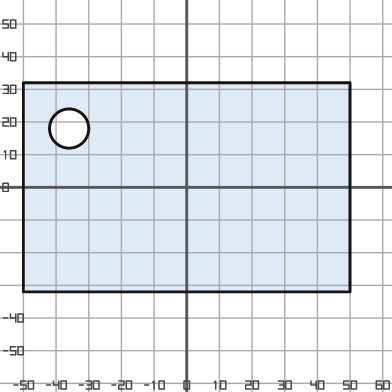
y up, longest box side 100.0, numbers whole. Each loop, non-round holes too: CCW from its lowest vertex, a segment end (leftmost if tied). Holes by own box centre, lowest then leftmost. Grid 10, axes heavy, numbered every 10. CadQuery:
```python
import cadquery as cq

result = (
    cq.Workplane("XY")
    .moveTo(-50.0, -32.0)
    .lineTo(50.0, -32.0)
    .lineTo(50.0, 32.0)
    .lineTo(-50.0, 32.0)
    .close()
    .moveTo(-36.0, 18.0)
    .circle(6.0)
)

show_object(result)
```